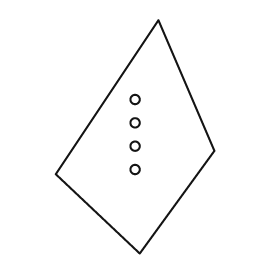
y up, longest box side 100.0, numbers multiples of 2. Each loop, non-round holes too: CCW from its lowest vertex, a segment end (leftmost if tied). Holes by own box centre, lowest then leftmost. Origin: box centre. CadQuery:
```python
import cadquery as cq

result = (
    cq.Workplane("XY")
    .moveTo(2.0, -50.0)
    .lineTo(34.0, -6.0)
    .lineTo(10.0, 50.0)
    .lineTo(-34.0, -16.0)
    .close()
    .moveTo(0.0, -14.0)
    .circle(2.0)
    .moveTo(0.0, -4.0)
    .circle(2.0)
    .moveTo(0.0, 6.0)
    .circle(2.0)
    .moveTo(0.0, 16.0)
    .circle(2.0)
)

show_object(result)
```